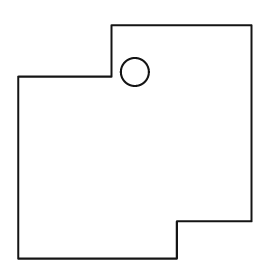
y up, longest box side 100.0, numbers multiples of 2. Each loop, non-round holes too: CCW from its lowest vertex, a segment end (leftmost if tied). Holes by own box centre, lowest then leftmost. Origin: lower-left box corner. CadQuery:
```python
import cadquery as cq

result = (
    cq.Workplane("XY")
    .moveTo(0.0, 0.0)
    .lineTo(68.0, 0.0)
    .lineTo(68.0, 16.0)
    .lineTo(100.0, 16.0)
    .lineTo(100.0, 100.0)
    .lineTo(40.0, 100.0)
    .lineTo(40.0, 78.0)
    .lineTo(0.0, 78.0)
    .close()
    .moveTo(50.0, 80.0)
    .circle(6.0)
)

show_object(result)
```